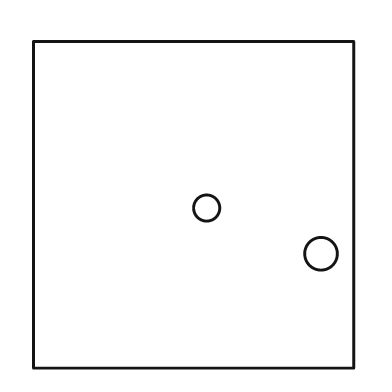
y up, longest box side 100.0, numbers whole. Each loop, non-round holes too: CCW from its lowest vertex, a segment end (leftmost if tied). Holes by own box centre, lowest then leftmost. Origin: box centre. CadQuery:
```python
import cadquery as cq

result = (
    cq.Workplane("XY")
    .moveTo(-49.0, -50.0)
    .lineTo(49.0, -50.0)
    .lineTo(49.0, 50.0)
    .lineTo(-49.0, 50.0)
    .close()
    .moveTo(39.0, -15.0)
    .circle(5.0)
    .moveTo(4.0, -1.0)
    .circle(4.0)
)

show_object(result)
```